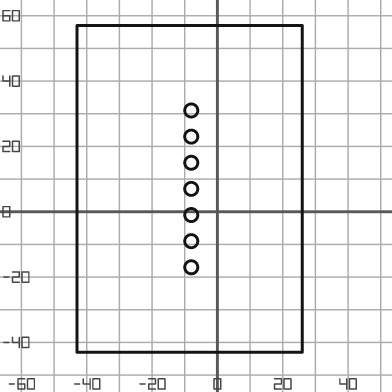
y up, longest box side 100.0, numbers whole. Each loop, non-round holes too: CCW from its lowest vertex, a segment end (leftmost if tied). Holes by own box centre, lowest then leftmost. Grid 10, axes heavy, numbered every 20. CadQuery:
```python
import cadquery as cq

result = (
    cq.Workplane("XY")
    .moveTo(-43.0, -43.0)
    .lineTo(26.0, -43.0)
    .lineTo(26.0, 57.0)
    .lineTo(-43.0, 57.0)
    .close()
    .moveTo(-8.0, -17.0)
    .circle(2.0)
    .moveTo(-8.0, -9.0)
    .circle(2.0)
    .moveTo(-8.0, -1.0)
    .circle(2.0)
    .moveTo(-8.0, 7.0)
    .circle(2.0)
    .moveTo(-8.0, 15.0)
    .circle(2.0)
    .moveTo(-8.0, 23.0)
    .circle(2.0)
    .moveTo(-8.0, 31.0)
    .circle(2.0)
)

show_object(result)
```